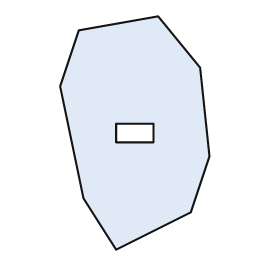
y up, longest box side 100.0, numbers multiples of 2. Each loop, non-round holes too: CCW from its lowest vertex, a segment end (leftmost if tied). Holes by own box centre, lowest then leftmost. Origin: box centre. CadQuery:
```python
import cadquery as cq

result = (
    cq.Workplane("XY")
    .moveTo(-8.0, -50.0)
    .lineTo(24.0, -34.0)
    .lineTo(32.0, -10.0)
    .lineTo(28.0, 28.0)
    .lineTo(10.0, 50.0)
    .lineTo(-24.0, 44.0)
    .lineTo(-32.0, 20.0)
    .lineTo(-22.0, -28.0)
    .close()
    .moveTo(-8.0, -4.0)
    .lineTo(8.0, -4.0)
    .lineTo(8.0, 4.0)
    .lineTo(-8.0, 4.0)
    .close()
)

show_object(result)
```